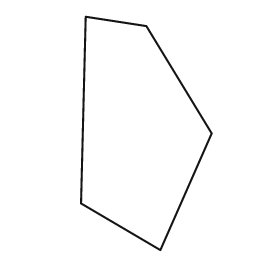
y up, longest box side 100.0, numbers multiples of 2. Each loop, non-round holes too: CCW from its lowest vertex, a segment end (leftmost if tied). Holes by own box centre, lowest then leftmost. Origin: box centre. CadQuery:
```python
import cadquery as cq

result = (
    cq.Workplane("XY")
    .moveTo(6.0, -50.0)
    .lineTo(28.0, 0.0)
    .lineTo(0.0, 46.0)
    .lineTo(-26.0, 50.0)
    .lineTo(-28.0, -30.0)
    .close()
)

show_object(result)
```